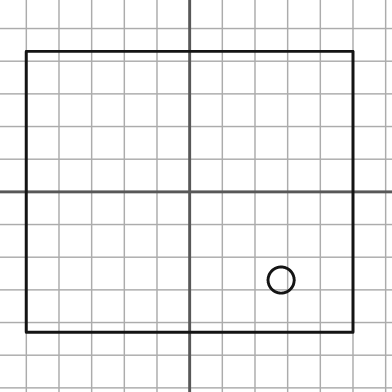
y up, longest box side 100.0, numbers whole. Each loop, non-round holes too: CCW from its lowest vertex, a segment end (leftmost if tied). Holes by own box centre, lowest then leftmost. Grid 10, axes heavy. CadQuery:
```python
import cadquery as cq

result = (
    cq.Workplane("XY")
    .moveTo(-50.0, -43.0)
    .lineTo(50.0, -43.0)
    .lineTo(50.0, 43.0)
    .lineTo(-50.0, 43.0)
    .close()
    .moveTo(28.0, -27.0)
    .circle(4.0)
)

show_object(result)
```